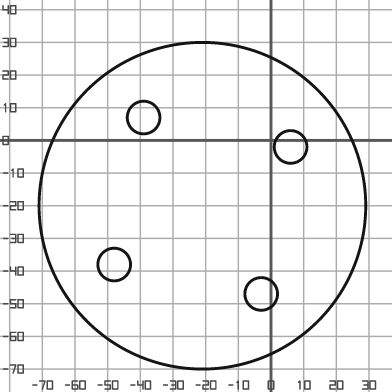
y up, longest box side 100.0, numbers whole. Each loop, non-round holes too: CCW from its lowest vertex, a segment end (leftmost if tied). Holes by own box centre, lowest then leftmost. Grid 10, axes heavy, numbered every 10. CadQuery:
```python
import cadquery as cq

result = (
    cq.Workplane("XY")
    .moveTo(-21.0, -20.0)
    .circle(50.0)
    .moveTo(-3.0, -47.0)
    .circle(5.0)
    .moveTo(-48.0, -38.0)
    .circle(5.0)
    .moveTo(6.0, -2.0)
    .circle(5.0)
    .moveTo(-39.0, 7.0)
    .circle(5.0)
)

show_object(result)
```